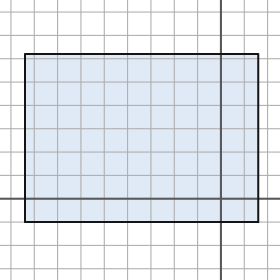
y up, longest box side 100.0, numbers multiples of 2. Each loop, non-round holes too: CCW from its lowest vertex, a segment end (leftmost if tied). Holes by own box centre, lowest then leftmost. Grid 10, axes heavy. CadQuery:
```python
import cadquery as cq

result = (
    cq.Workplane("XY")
    .moveTo(-84.0, -10.0)
    .lineTo(16.0, -10.0)
    .lineTo(16.0, 62.0)
    .lineTo(-84.0, 62.0)
    .close()
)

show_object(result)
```